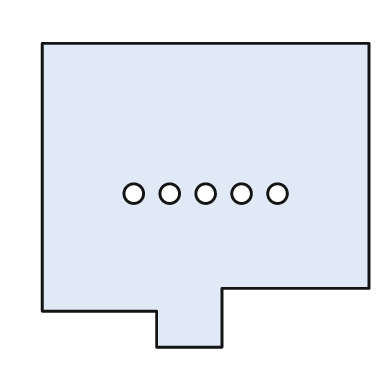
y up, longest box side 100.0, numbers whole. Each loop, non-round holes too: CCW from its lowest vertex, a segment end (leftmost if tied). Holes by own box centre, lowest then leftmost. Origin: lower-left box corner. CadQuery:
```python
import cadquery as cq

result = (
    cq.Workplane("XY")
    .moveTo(35.0, 0.0)
    .lineTo(55.0, 0.0)
    .lineTo(55.0, 18.0)
    .lineTo(100.0, 18.0)
    .lineTo(100.0, 93.0)
    .lineTo(0.0, 93.0)
    .lineTo(0.0, 11.0)
    .lineTo(35.0, 11.0)
    .close()
    .moveTo(28.0, 47.0)
    .circle(3.0)
    .moveTo(39.0, 47.0)
    .circle(3.0)
    .moveTo(50.0, 47.0)
    .circle(3.0)
    .moveTo(61.0, 47.0)
    .circle(3.0)
    .moveTo(72.0, 47.0)
    .circle(3.0)
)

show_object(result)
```